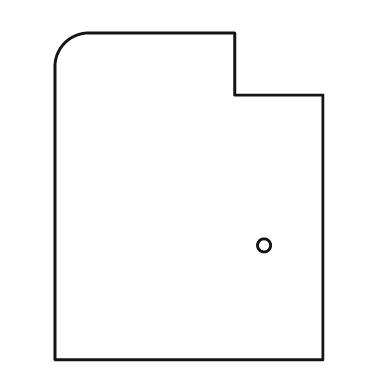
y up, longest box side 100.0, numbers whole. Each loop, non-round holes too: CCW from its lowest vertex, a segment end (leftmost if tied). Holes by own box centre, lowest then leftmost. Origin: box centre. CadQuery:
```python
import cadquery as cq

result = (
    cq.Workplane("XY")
    .moveTo(-41.0, -50.0)
    .lineTo(41.0, -50.0)
    .lineTo(41.0, 31.0)
    .lineTo(14.0, 31.0)
    .lineTo(14.0, 50.0)
    .lineTo(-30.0, 50.0)
    .threePointArc((-38.0, 47.0), (-41.0, 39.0))
    .close()
    .moveTo(23.0, -15.0)
    .circle(2.0)
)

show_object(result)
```